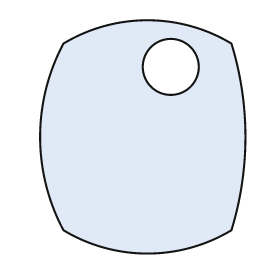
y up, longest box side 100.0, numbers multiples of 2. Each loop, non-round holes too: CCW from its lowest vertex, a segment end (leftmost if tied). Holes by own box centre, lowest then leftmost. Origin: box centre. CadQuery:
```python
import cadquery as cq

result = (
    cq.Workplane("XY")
    .moveTo(-34.0, -40.0)
    .threePointArc((2.0, -50.0), (38.0, -40.0))
    .threePointArc((44.0, 0.0), (38.0, 40.0))
    .threePointArc((2.0, 50.0), (-34.0, 40.0))
    .threePointArc((-44.0, 0.0), (-34.0, -40.0))
    .close()
    .moveTo(12.0, 30.0)
    .circle(12.0)
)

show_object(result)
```